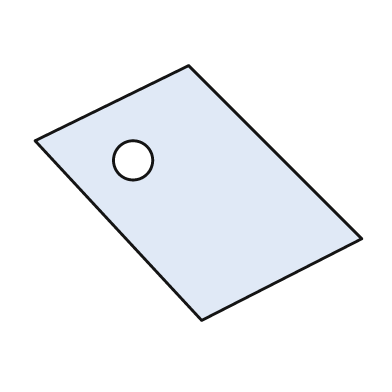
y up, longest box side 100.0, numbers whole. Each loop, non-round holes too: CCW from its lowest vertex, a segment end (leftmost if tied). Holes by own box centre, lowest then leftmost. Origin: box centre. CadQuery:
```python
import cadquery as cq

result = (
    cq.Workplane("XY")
    .moveTo(1.0, -39.0)
    .lineTo(50.0, -14.0)
    .lineTo(-3.0, 39.0)
    .lineTo(-50.0, 16.0)
    .close()
    .moveTo(-20.0, 10.0)
    .circle(6.0)
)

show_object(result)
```